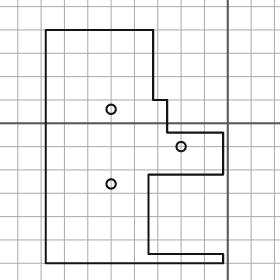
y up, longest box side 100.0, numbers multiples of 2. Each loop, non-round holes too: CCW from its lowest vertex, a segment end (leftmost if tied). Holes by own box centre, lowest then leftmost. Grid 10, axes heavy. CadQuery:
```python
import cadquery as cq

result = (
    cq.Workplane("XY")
    .moveTo(-78.0, -60.0)
    .lineTo(-2.0, -60.0)
    .lineTo(-2.0, -56.0)
    .lineTo(-34.0, -56.0)
    .lineTo(-34.0, -22.0)
    .lineTo(-2.0, -22.0)
    .lineTo(-2.0, -4.0)
    .lineTo(-26.0, -4.0)
    .lineTo(-26.0, 10.0)
    .lineTo(-32.0, 10.0)
    .lineTo(-32.0, 40.0)
    .lineTo(-78.0, 40.0)
    .close()
    .moveTo(-50.0, -26.0)
    .circle(2.0)
    .moveTo(-20.0, -10.0)
    .circle(2.0)
    .moveTo(-50.0, 6.0)
    .circle(2.0)
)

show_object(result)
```